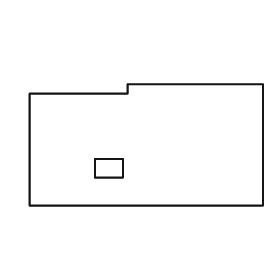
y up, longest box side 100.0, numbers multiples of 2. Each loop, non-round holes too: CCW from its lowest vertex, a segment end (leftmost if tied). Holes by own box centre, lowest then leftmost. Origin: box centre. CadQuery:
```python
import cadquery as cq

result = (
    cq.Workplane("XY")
    .moveTo(-50.0, -26.0)
    .lineTo(50.0, -26.0)
    .lineTo(50.0, 26.0)
    .lineTo(-8.0, 26.0)
    .lineTo(-8.0, 22.0)
    .lineTo(-50.0, 22.0)
    .close()
    .moveTo(-22.0, -14.0)
    .lineTo(-10.0, -14.0)
    .lineTo(-10.0, -6.0)
    .lineTo(-22.0, -6.0)
    .close()
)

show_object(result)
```